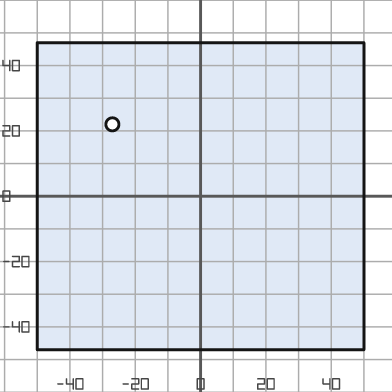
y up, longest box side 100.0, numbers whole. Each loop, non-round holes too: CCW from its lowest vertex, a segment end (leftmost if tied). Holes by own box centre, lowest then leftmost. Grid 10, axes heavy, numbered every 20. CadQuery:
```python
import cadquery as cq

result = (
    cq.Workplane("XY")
    .moveTo(-50.0, -47.0)
    .lineTo(50.0, -47.0)
    .lineTo(50.0, 47.0)
    .lineTo(-50.0, 47.0)
    .close()
    .moveTo(-27.0, 22.0)
    .circle(2.0)
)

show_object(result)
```